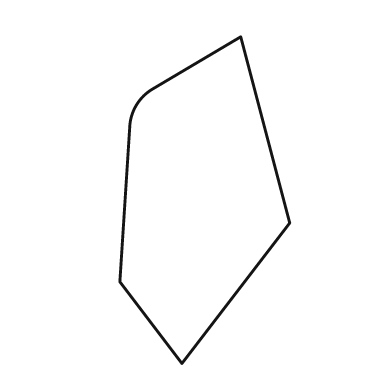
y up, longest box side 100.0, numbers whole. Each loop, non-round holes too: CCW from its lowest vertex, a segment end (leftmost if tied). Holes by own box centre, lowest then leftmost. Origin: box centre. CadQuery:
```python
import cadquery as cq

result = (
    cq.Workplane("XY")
    .moveTo(-7.0, -50.0)
    .lineTo(26.0, -7.0)
    .lineTo(11.0, 50.0)
    .lineTo(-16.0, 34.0)
    .threePointArc((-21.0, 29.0), (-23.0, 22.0))
    .lineTo(-26.0, -25.0)
    .close()
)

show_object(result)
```